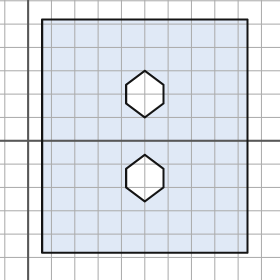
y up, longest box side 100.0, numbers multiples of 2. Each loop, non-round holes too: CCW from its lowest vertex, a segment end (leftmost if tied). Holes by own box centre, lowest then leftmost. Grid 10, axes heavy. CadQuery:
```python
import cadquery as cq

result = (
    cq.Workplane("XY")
    .moveTo(6.0, -48.0)
    .lineTo(94.0, -48.0)
    .lineTo(94.0, 52.0)
    .lineTo(6.0, 52.0)
    .close()
    .moveTo(50.0, -26.0)
    .lineTo(58.0, -20.0)
    .lineTo(58.0, -12.0)
    .lineTo(50.0, -6.0)
    .lineTo(42.0, -12.0)
    .lineTo(42.0, -20.0)
    .close()
    .moveTo(50.0, 10.0)
    .lineTo(58.0, 16.0)
    .lineTo(58.0, 24.0)
    .lineTo(50.0, 30.0)
    .lineTo(42.0, 24.0)
    .lineTo(42.0, 16.0)
    .close()
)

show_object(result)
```